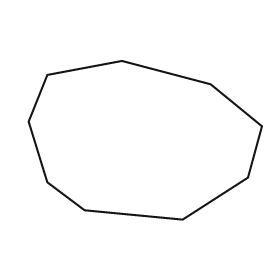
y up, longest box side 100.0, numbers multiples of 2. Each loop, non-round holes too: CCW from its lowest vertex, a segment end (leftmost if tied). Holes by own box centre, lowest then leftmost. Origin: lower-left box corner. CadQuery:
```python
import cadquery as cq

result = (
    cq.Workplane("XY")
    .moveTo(66.0, 0.0)
    .lineTo(94.0, 18.0)
    .lineTo(100.0, 40.0)
    .lineTo(78.0, 58.0)
    .lineTo(40.0, 68.0)
    .lineTo(8.0, 62.0)
    .lineTo(0.0, 42.0)
    .lineTo(8.0, 16.0)
    .lineTo(24.0, 4.0)
    .close()
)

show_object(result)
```